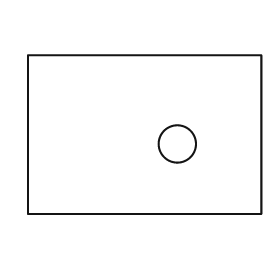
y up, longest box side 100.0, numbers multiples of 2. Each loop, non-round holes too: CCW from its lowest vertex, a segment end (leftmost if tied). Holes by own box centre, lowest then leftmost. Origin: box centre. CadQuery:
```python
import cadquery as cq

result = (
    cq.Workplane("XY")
    .moveTo(-50.0, -34.0)
    .lineTo(50.0, -34.0)
    .lineTo(50.0, 34.0)
    .lineTo(-50.0, 34.0)
    .close()
    .moveTo(14.0, -4.0)
    .circle(8.0)
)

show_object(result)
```